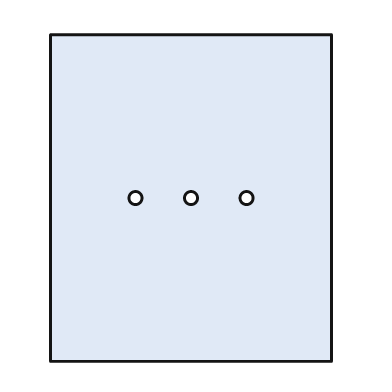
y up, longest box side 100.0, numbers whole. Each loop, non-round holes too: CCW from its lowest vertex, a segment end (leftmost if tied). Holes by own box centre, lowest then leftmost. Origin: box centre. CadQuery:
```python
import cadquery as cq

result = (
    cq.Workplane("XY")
    .moveTo(-43.0, -50.0)
    .lineTo(43.0, -50.0)
    .lineTo(43.0, 50.0)
    .lineTo(-43.0, 50.0)
    .close()
    .moveTo(-17.0, 0.0)
    .circle(2.0)
    .moveTo(0.0, 0.0)
    .circle(2.0)
    .moveTo(17.0, 0.0)
    .circle(2.0)
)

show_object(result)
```